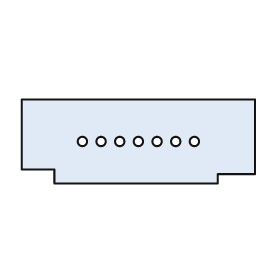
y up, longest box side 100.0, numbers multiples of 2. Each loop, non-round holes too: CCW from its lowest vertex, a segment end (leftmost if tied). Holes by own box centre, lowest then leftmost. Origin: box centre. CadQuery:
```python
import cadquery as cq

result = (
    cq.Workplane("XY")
    .moveTo(-36.0, -18.0)
    .lineTo(34.0, -18.0)
    .lineTo(34.0, -14.0)
    .lineTo(50.0, -14.0)
    .lineTo(50.0, 18.0)
    .lineTo(-50.0, 18.0)
    .lineTo(-50.0, -12.0)
    .lineTo(-36.0, -12.0)
    .close()
    .moveTo(-24.0, 0.0)
    .circle(2.0)
    .moveTo(-16.0, 0.0)
    .circle(2.0)
    .moveTo(-8.0, 0.0)
    .circle(2.0)
    .moveTo(0.0, 0.0)
    .circle(2.0)
    .moveTo(8.0, 0.0)
    .circle(2.0)
    .moveTo(16.0, 0.0)
    .circle(2.0)
    .moveTo(24.0, 0.0)
    .circle(2.0)
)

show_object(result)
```